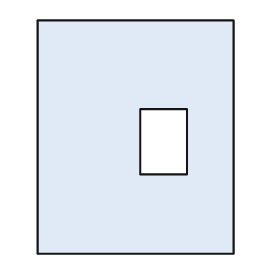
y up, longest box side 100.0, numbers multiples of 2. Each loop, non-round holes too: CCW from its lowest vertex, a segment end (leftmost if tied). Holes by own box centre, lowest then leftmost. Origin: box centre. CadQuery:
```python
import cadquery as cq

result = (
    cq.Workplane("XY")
    .moveTo(-42.0, -50.0)
    .lineTo(42.0, -50.0)
    .lineTo(42.0, 50.0)
    .lineTo(-42.0, 50.0)
    .close()
    .moveTo(2.0, -16.0)
    .lineTo(22.0, -16.0)
    .lineTo(22.0, 12.0)
    .lineTo(2.0, 12.0)
    .close()
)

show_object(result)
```